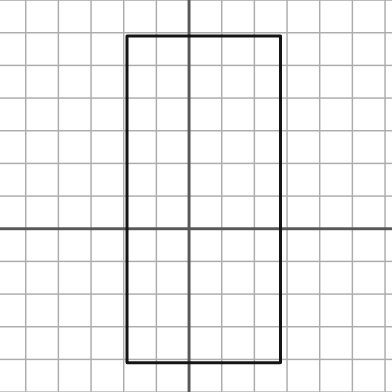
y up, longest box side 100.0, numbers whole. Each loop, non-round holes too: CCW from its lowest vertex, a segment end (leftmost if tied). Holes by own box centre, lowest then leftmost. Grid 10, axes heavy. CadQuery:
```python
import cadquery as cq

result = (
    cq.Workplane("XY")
    .moveTo(-19.0, -41.0)
    .lineTo(28.0, -41.0)
    .lineTo(28.0, 59.0)
    .lineTo(-19.0, 59.0)
    .close()
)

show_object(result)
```